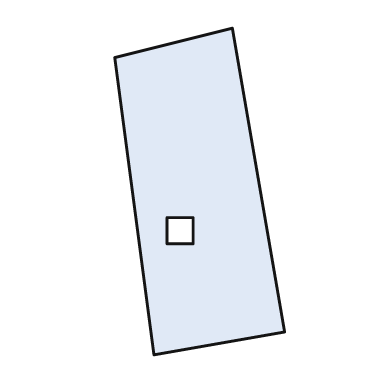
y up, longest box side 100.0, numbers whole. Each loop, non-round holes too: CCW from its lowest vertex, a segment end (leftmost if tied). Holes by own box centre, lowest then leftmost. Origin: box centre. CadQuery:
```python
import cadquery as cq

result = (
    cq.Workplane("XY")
    .moveTo(-14.0, -50.0)
    .lineTo(26.0, -43.0)
    .lineTo(10.0, 50.0)
    .lineTo(-26.0, 41.0)
    .close()
    .moveTo(-10.0, -16.0)
    .lineTo(-2.0, -16.0)
    .lineTo(-2.0, -8.0)
    .lineTo(-10.0, -8.0)
    .close()
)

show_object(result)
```